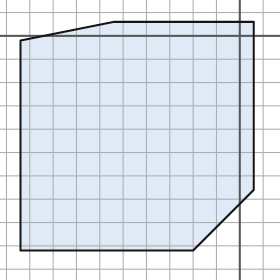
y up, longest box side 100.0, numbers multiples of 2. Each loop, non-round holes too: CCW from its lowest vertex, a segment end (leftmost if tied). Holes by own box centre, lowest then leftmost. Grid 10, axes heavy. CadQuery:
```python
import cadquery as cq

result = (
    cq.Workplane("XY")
    .moveTo(-94.0, -92.0)
    .lineTo(-20.0, -92.0)
    .lineTo(6.0, -66.0)
    .lineTo(6.0, 6.0)
    .lineTo(-54.0, 6.0)
    .lineTo(-94.0, -2.0)
    .close()
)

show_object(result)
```